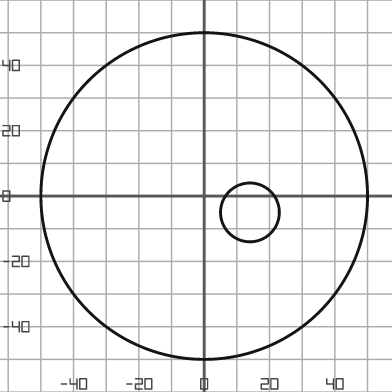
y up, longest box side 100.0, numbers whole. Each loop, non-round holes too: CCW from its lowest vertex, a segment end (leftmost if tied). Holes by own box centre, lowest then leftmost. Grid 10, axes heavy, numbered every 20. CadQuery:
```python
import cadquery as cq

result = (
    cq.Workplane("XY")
    .moveTo(0.0, 0.0)
    .circle(50.0)
    .moveTo(14.0, -5.0)
    .circle(9.0)
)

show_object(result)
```